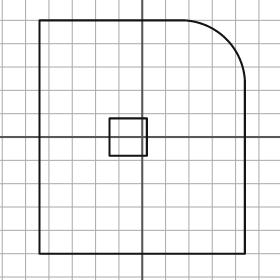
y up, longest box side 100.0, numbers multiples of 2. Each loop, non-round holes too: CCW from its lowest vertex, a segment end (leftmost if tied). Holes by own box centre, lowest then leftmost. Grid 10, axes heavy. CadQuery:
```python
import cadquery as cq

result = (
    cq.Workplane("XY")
    .moveTo(-44.0, -50.0)
    .lineTo(44.0, -50.0)
    .lineTo(44.0, 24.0)
    .threePointArc((36.0, 42.0), (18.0, 50.0))
    .lineTo(-44.0, 50.0)
    .close()
    .moveTo(-14.0, -8.0)
    .lineTo(2.0, -8.0)
    .lineTo(2.0, 8.0)
    .lineTo(-14.0, 8.0)
    .close()
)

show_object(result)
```